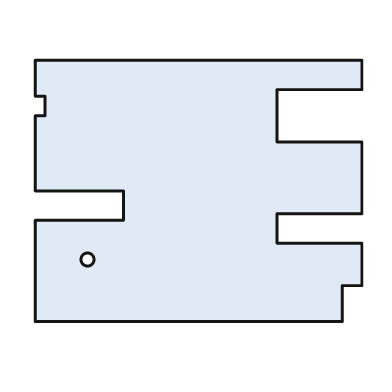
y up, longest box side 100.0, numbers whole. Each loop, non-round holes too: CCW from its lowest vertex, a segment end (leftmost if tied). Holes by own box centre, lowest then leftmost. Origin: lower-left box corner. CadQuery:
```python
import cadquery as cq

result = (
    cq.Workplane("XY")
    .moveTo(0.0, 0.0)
    .lineTo(94.0, 0.0)
    .lineTo(94.0, 11.0)
    .lineTo(100.0, 11.0)
    .lineTo(100.0, 24.0)
    .lineTo(74.0, 24.0)
    .lineTo(74.0, 33.0)
    .lineTo(100.0, 33.0)
    .lineTo(100.0, 55.0)
    .lineTo(74.0, 55.0)
    .lineTo(74.0, 71.0)
    .lineTo(100.0, 71.0)
    .lineTo(100.0, 80.0)
    .lineTo(0.0, 80.0)
    .lineTo(0.0, 69.0)
    .lineTo(3.0, 69.0)
    .lineTo(3.0, 63.0)
    .lineTo(0.0, 63.0)
    .lineTo(0.0, 40.0)
    .lineTo(27.0, 40.0)
    .lineTo(27.0, 31.0)
    .lineTo(0.0, 31.0)
    .close()
    .moveTo(16.0, 19.0)
    .circle(2.0)
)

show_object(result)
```